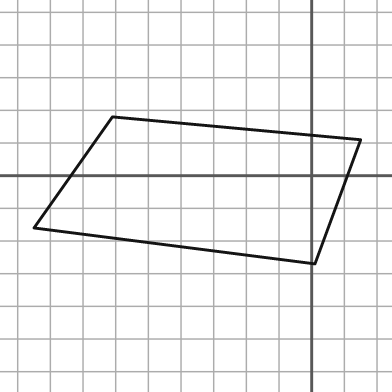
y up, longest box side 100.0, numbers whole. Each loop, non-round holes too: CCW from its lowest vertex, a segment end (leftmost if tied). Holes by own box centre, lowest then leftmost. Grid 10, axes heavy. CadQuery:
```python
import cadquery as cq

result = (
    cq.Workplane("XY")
    .moveTo(1.0, -27.0)
    .lineTo(15.0, 11.0)
    .lineTo(-61.0, 18.0)
    .lineTo(-85.0, -16.0)
    .close()
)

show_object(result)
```